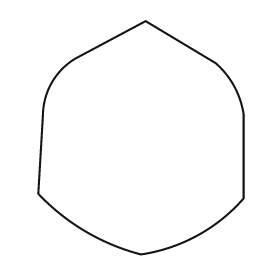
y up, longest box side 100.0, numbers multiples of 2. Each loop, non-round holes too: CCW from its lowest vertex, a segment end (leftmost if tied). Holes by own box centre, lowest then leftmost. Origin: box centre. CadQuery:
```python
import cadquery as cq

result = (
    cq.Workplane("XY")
    .moveTo(0.0, -50.0)
    .threePointArc((24.0, -42.0), (44.0, -26.0))
    .lineTo(44.0, 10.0)
    .threePointArc((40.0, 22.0), (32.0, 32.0))
    .lineTo(2.0, 50.0)
    .lineTo(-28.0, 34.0)
    .threePointArc((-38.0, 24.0), (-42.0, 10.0))
    .lineTo(-44.0, -24.0)
    .threePointArc((-24.0, -40.0), (0.0, -50.0))
    .close()
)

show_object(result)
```